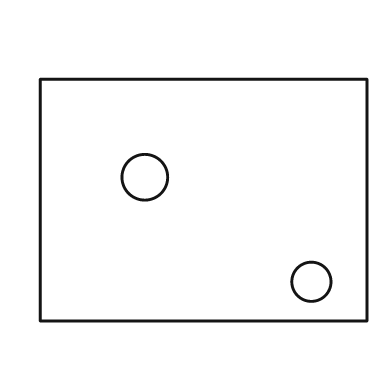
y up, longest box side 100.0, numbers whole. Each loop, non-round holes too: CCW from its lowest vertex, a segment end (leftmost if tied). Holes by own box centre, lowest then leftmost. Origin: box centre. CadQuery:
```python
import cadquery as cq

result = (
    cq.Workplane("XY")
    .moveTo(-50.0, -37.0)
    .lineTo(50.0, -37.0)
    .lineTo(50.0, 37.0)
    .lineTo(-50.0, 37.0)
    .close()
    .moveTo(33.0, -25.0)
    .circle(6.0)
    .moveTo(-18.0, 7.0)
    .circle(7.0)
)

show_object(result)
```